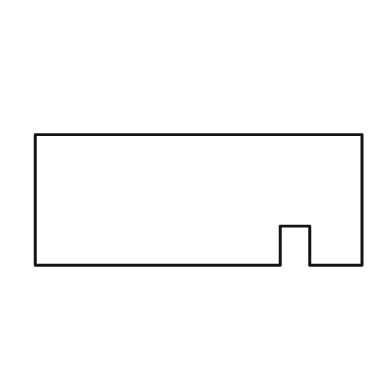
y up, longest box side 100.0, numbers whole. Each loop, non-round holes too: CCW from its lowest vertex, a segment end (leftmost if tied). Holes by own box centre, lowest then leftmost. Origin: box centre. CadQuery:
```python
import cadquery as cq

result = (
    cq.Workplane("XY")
    .moveTo(-50.0, -20.0)
    .lineTo(25.0, -20.0)
    .lineTo(25.0, -8.0)
    .lineTo(34.0, -8.0)
    .lineTo(34.0, -20.0)
    .lineTo(50.0, -20.0)
    .lineTo(50.0, 20.0)
    .lineTo(-50.0, 20.0)
    .close()
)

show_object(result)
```